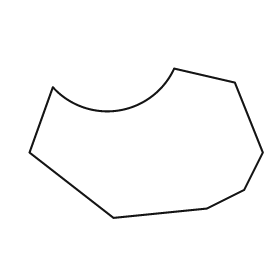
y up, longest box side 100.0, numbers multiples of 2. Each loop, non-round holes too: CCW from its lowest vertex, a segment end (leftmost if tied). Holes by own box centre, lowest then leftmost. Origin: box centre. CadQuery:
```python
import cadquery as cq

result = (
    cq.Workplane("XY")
    .moveTo(-14.0, -32.0)
    .lineTo(26.0, -28.0)
    .lineTo(42.0, -20.0)
    .lineTo(50.0, -4.0)
    .lineTo(38.0, 26.0)
    .lineTo(12.0, 32.0)
    .threePointArc((-12.0, 14.0), (-40.0, 24.0))
    .lineTo(-50.0, -4.0)
    .close()
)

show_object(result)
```